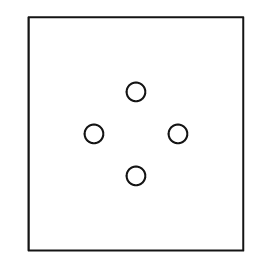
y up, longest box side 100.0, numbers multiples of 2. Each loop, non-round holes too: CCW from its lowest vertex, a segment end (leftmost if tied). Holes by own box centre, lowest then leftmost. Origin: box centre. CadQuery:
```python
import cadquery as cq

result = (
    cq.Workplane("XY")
    .moveTo(-46.0, -50.0)
    .lineTo(46.0, -50.0)
    .lineTo(46.0, 50.0)
    .lineTo(-46.0, 50.0)
    .close()
    .moveTo(0.0, -18.0)
    .circle(4.0)
    .moveTo(-18.0, 0.0)
    .circle(4.0)
    .moveTo(18.0, 0.0)
    .circle(4.0)
    .moveTo(0.0, 18.0)
    .circle(4.0)
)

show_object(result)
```